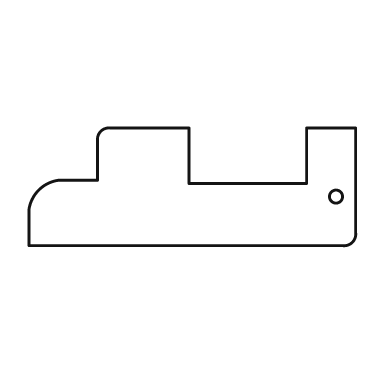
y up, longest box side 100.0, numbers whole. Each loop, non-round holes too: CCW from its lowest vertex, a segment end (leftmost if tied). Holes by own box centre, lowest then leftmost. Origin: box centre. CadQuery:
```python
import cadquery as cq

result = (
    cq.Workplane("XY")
    .moveTo(-50.0, -18.0)
    .lineTo(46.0, -18.0)
    .threePointArc((49.0, -17.0), (50.0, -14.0))
    .lineTo(50.0, 18.0)
    .lineTo(35.0, 18.0)
    .lineTo(35.0, 1.0)
    .lineTo(-1.0, 1.0)
    .lineTo(-1.0, 18.0)
    .lineTo(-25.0, 18.0)
    .threePointArc((-28.0, 17.0), (-29.0, 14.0))
    .lineTo(-29.0, 2.0)
    .lineTo(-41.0, 2.0)
    .threePointArc((-47.0, -1.0), (-50.0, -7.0))
    .close()
    .moveTo(44.0, -3.0)
    .circle(2.0)
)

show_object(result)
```